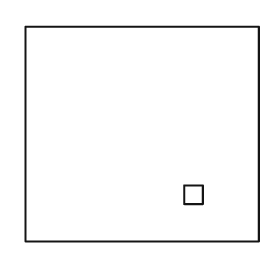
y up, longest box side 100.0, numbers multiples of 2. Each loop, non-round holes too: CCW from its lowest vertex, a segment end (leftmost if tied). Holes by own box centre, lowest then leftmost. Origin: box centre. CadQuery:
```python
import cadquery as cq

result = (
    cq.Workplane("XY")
    .moveTo(-50.0, -46.0)
    .lineTo(50.0, -46.0)
    .lineTo(50.0, 46.0)
    .lineTo(-50.0, 46.0)
    .close()
    .moveTo(18.0, -30.0)
    .lineTo(26.0, -30.0)
    .lineTo(26.0, -22.0)
    .lineTo(18.0, -22.0)
    .close()
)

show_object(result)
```